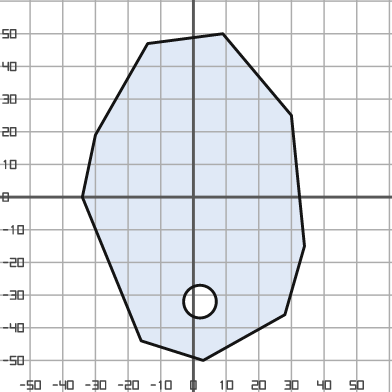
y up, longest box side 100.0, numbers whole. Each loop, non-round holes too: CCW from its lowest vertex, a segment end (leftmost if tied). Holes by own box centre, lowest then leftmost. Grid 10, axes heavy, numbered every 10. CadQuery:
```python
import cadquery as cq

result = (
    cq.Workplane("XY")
    .moveTo(3.0, -50.0)
    .lineTo(28.0, -36.0)
    .lineTo(34.0, -15.0)
    .lineTo(30.0, 25.0)
    .lineTo(9.0, 50.0)
    .lineTo(-14.0, 47.0)
    .lineTo(-30.0, 19.0)
    .lineTo(-34.0, 0.0)
    .lineTo(-16.0, -44.0)
    .close()
    .moveTo(2.0, -32.0)
    .circle(5.0)
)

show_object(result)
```